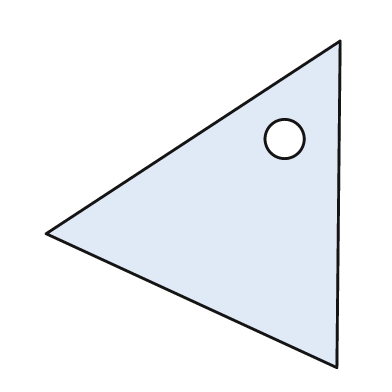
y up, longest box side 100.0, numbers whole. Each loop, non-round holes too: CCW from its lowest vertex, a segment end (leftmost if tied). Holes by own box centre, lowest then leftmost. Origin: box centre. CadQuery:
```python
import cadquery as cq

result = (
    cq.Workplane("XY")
    .moveTo(44.0, -50.0)
    .lineTo(45.0, 50.0)
    .lineTo(-45.0, -9.0)
    .close()
    .moveTo(28.0, 20.0)
    .circle(6.0)
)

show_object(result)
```